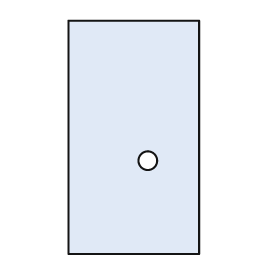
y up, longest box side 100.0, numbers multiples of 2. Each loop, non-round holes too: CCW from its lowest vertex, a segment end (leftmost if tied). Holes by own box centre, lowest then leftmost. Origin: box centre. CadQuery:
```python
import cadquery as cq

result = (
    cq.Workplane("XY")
    .moveTo(-28.0, -50.0)
    .lineTo(28.0, -50.0)
    .lineTo(28.0, 50.0)
    .lineTo(-28.0, 50.0)
    .close()
    .moveTo(6.0, -10.0)
    .circle(4.0)
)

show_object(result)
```